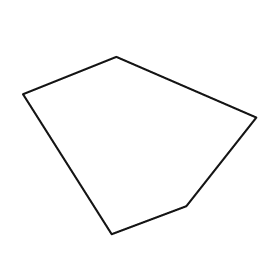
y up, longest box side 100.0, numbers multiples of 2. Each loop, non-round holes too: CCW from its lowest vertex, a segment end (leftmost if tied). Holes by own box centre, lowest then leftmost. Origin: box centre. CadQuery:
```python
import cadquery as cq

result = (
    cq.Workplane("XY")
    .moveTo(-12.0, -38.0)
    .lineTo(20.0, -26.0)
    .lineTo(50.0, 12.0)
    .lineTo(-10.0, 38.0)
    .lineTo(-50.0, 22.0)
    .close()
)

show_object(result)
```